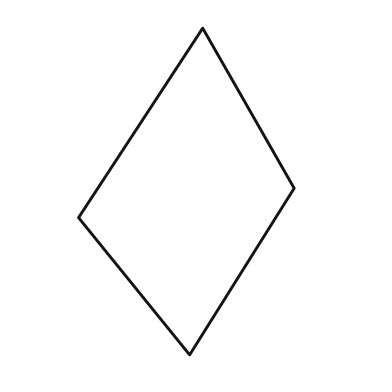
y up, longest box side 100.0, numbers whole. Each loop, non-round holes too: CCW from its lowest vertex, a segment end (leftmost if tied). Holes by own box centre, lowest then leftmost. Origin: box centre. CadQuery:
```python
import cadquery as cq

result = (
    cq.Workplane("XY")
    .moveTo(1.0, -50.0)
    .lineTo(33.0, 1.0)
    .lineTo(5.0, 50.0)
    .lineTo(-33.0, -8.0)
    .close()
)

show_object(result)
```